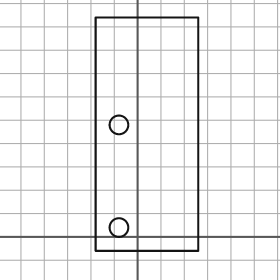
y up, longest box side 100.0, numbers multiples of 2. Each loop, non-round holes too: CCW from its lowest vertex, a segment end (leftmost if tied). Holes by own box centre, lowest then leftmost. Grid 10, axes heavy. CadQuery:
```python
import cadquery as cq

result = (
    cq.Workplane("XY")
    .moveTo(-18.0, -6.0)
    .lineTo(26.0, -6.0)
    .lineTo(26.0, 94.0)
    .lineTo(-18.0, 94.0)
    .close()
    .moveTo(-8.0, 4.0)
    .circle(4.0)
    .moveTo(-8.0, 48.0)
    .circle(4.0)
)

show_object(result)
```